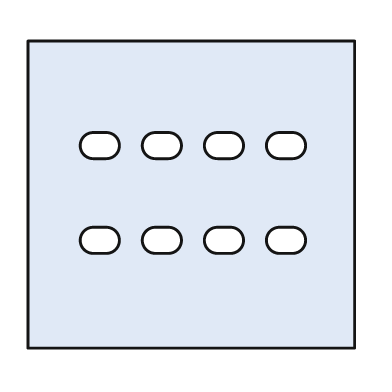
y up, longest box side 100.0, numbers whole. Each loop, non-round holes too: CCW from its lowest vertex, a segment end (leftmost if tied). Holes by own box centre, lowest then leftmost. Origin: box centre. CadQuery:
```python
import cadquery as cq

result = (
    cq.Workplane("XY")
    .moveTo(-50.0, -47.0)
    .lineTo(50.0, -47.0)
    .lineTo(50.0, 47.0)
    .lineTo(-50.0, 47.0)
    .close()
    .moveTo(-30.0, -18.0)
    .lineTo(-26.0, -18.0)
    .threePointArc((-22.0, -14.0), (-26.0, -10.0))
    .lineTo(-30.0, -10.0)
    .threePointArc((-34.0, -14.0), (-30.0, -18.0))
    .close()
    .moveTo(-11.0, -18.0)
    .lineTo(-7.0, -18.0)
    .threePointArc((-3.0, -14.0), (-7.0, -10.0))
    .lineTo(-11.0, -10.0)
    .threePointArc((-15.0, -14.0), (-11.0, -18.0))
    .close()
    .moveTo(8.0, -18.0)
    .lineTo(12.0, -18.0)
    .threePointArc((16.0, -14.0), (12.0, -10.0))
    .lineTo(8.0, -10.0)
    .threePointArc((4.0, -14.0), (8.0, -18.0))
    .close()
    .moveTo(27.0, -18.0)
    .lineTo(31.0, -18.0)
    .threePointArc((35.0, -14.0), (31.0, -10.0))
    .lineTo(27.0, -10.0)
    .threePointArc((23.0, -14.0), (27.0, -18.0))
    .close()
    .moveTo(-30.0, 11.0)
    .lineTo(-26.0, 11.0)
    .threePointArc((-22.0, 15.0), (-26.0, 19.0))
    .lineTo(-30.0, 19.0)
    .threePointArc((-34.0, 15.0), (-30.0, 11.0))
    .close()
    .moveTo(-11.0, 11.0)
    .lineTo(-7.0, 11.0)
    .threePointArc((-3.0, 15.0), (-7.0, 19.0))
    .lineTo(-11.0, 19.0)
    .threePointArc((-15.0, 15.0), (-11.0, 11.0))
    .close()
    .moveTo(8.0, 11.0)
    .lineTo(12.0, 11.0)
    .threePointArc((16.0, 15.0), (12.0, 19.0))
    .lineTo(8.0, 19.0)
    .threePointArc((4.0, 15.0), (8.0, 11.0))
    .close()
    .moveTo(27.0, 11.0)
    .lineTo(31.0, 11.0)
    .threePointArc((35.0, 15.0), (31.0, 19.0))
    .lineTo(27.0, 19.0)
    .threePointArc((23.0, 15.0), (27.0, 11.0))
    .close()
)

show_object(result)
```